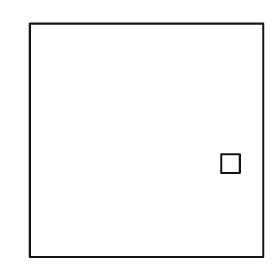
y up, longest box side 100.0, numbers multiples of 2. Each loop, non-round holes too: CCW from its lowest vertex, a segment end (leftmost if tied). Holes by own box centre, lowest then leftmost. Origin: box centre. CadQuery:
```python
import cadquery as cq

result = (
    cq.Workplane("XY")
    .moveTo(-50.0, -50.0)
    .lineTo(50.0, -50.0)
    .lineTo(50.0, 50.0)
    .lineTo(-50.0, 50.0)
    .close()
    .moveTo(32.0, -14.0)
    .lineTo(40.0, -14.0)
    .lineTo(40.0, -6.0)
    .lineTo(32.0, -6.0)
    .close()
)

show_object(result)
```